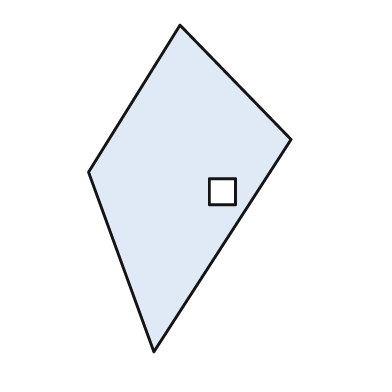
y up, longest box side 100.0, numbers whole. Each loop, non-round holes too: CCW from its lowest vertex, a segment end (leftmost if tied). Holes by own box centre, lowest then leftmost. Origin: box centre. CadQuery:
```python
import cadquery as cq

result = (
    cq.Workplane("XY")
    .moveTo(-11.0, -50.0)
    .lineTo(31.0, 15.0)
    .lineTo(-3.0, 50.0)
    .lineTo(-31.0, 5.0)
    .close()
    .moveTo(6.0, -5.0)
    .lineTo(14.0, -5.0)
    .lineTo(14.0, 3.0)
    .lineTo(6.0, 3.0)
    .close()
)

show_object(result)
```